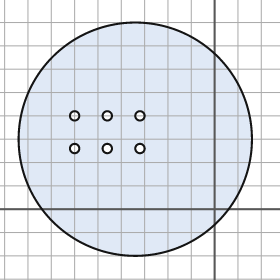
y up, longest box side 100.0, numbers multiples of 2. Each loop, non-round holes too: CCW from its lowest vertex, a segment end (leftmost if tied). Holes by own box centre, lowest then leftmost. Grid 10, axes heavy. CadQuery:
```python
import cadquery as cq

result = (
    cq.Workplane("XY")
    .moveTo(-34.0, 30.0)
    .circle(50.0)
    .moveTo(-60.0, 26.0)
    .circle(2.0)
    .moveTo(-46.0, 26.0)
    .circle(2.0)
    .moveTo(-32.0, 26.0)
    .circle(2.0)
    .moveTo(-60.0, 40.0)
    .circle(2.0)
    .moveTo(-46.0, 40.0)
    .circle(2.0)
    .moveTo(-32.0, 40.0)
    .circle(2.0)
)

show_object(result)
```